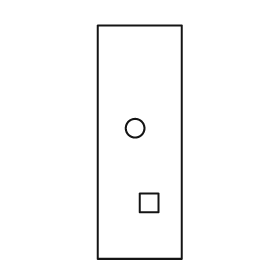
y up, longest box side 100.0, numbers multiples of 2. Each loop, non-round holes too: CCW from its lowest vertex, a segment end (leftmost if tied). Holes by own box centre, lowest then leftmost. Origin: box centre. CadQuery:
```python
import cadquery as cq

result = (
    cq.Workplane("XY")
    .moveTo(-18.0, -50.0)
    .lineTo(18.0, -50.0)
    .lineTo(18.0, 50.0)
    .lineTo(-18.0, 50.0)
    .close()
    .moveTo(0.0, -30.0)
    .lineTo(8.0, -30.0)
    .lineTo(8.0, -22.0)
    .lineTo(0.0, -22.0)
    .close()
    .moveTo(-2.0, 6.0)
    .circle(4.0)
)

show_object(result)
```